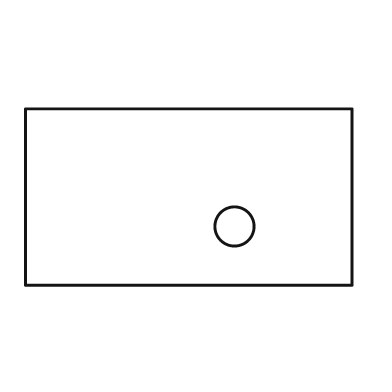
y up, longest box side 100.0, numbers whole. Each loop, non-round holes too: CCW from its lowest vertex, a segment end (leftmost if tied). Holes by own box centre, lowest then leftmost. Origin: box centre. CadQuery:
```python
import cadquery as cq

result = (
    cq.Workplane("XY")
    .moveTo(-50.0, -27.0)
    .lineTo(50.0, -27.0)
    .lineTo(50.0, 27.0)
    .lineTo(-50.0, 27.0)
    .close()
    .moveTo(14.0, -9.0)
    .circle(6.0)
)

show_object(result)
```